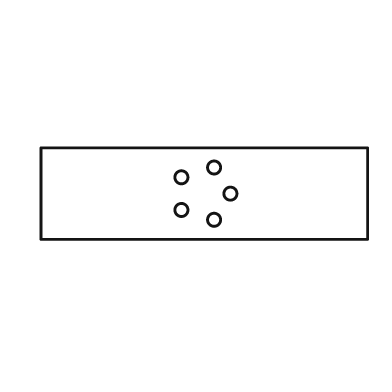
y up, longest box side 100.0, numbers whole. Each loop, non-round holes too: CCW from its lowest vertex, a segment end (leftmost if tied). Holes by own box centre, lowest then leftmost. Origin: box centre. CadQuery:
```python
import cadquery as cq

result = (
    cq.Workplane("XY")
    .moveTo(-50.0, -14.0)
    .lineTo(50.0, -14.0)
    .lineTo(50.0, 14.0)
    .lineTo(-50.0, 14.0)
    .close()
    .moveTo(3.0, -8.0)
    .circle(2.0)
    .moveTo(-7.0, -5.0)
    .circle(2.0)
    .moveTo(8.0, 0.0)
    .circle(2.0)
    .moveTo(-7.0, 5.0)
    .circle(2.0)
    .moveTo(3.0, 8.0)
    .circle(2.0)
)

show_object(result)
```